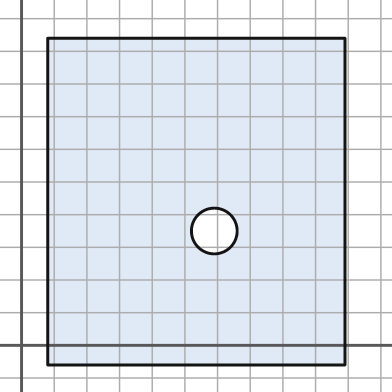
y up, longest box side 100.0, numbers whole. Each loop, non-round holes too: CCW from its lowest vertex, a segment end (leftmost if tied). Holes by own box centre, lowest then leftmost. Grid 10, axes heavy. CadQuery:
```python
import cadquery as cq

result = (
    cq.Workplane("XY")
    .moveTo(8.0, -6.0)
    .lineTo(99.0, -6.0)
    .lineTo(99.0, 94.0)
    .lineTo(8.0, 94.0)
    .close()
    .moveTo(59.0, 35.0)
    .circle(7.0)
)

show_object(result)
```